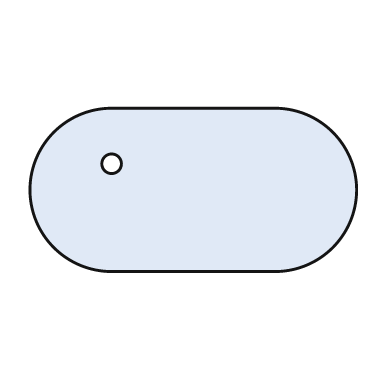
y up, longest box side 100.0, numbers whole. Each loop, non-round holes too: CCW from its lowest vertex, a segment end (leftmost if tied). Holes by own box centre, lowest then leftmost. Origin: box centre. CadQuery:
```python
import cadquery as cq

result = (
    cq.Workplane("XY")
    .moveTo(-25.0, -25.0)
    .lineTo(25.0, -25.0)
    .threePointArc((50.0, 0.0), (25.0, 25.0))
    .lineTo(-25.0, 25.0)
    .threePointArc((-50.0, 0.0), (-25.0, -25.0))
    .close()
    .moveTo(-25.0, 8.0)
    .circle(3.0)
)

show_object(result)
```